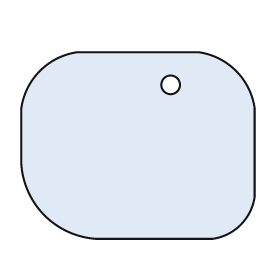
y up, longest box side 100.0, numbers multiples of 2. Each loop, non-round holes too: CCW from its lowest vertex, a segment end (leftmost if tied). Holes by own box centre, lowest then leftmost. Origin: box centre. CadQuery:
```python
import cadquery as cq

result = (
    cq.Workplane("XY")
    .moveTo(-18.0, -40.0)
    .lineTo(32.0, -40.0)
    .threePointArc((44.0, -34.0), (50.0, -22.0))
    .lineTo(50.0, 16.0)
    .threePointArc((42.0, 32.0), (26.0, 40.0))
    .lineTo(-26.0, 40.0)
    .threePointArc((-42.0, 32.0), (-50.0, 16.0))
    .lineTo(-50.0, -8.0)
    .threePointArc((-40.0, -30.0), (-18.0, -40.0))
    .close()
    .moveTo(14.0, 26.0)
    .circle(4.0)
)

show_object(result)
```